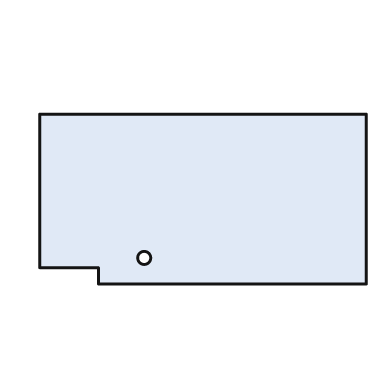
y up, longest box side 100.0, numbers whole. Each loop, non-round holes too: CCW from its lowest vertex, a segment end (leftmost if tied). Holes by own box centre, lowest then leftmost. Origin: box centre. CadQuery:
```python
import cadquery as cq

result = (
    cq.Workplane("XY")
    .moveTo(-32.0, -26.0)
    .lineTo(50.0, -26.0)
    .lineTo(50.0, 26.0)
    .lineTo(-50.0, 26.0)
    .lineTo(-50.0, -21.0)
    .lineTo(-32.0, -21.0)
    .close()
    .moveTo(-18.0, -18.0)
    .circle(2.0)
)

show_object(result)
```